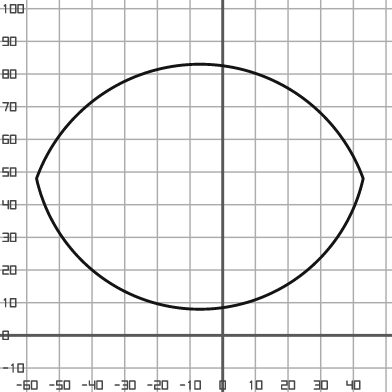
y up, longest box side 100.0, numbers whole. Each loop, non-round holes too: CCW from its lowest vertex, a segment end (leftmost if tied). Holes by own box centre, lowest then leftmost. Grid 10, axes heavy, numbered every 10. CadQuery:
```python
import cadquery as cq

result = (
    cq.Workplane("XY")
    .moveTo(-57.0, 48.0)
    .threePointArc((-7.0, 8.0), (43.0, 48.0))
    .threePointArc((-7.0, 83.0), (-57.0, 48.0))
    .close()
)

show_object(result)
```